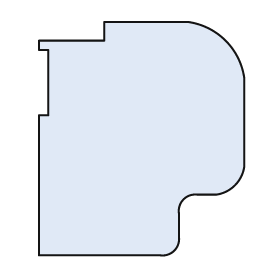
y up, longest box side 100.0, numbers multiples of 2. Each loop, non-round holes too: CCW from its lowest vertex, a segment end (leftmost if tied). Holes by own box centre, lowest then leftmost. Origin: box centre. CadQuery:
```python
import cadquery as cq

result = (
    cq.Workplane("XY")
    .moveTo(-44.0, -50.0)
    .lineTo(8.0, -50.0)
    .threePointArc((14.0, -48.0), (16.0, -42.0))
    .lineTo(16.0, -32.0)
    .threePointArc((18.0, -26.0), (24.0, -24.0))
    .lineTo(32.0, -24.0)
    .threePointArc((40.0, -20.0), (44.0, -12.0))
    .lineTo(44.0, 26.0)
    .threePointArc((36.0, 42.0), (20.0, 50.0))
    .lineTo(-16.0, 50.0)
    .lineTo(-16.0, 42.0)
    .lineTo(-44.0, 42.0)
    .lineTo(-44.0, 38.0)
    .lineTo(-40.0, 38.0)
    .lineTo(-40.0, 10.0)
    .lineTo(-44.0, 10.0)
    .close()
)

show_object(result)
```